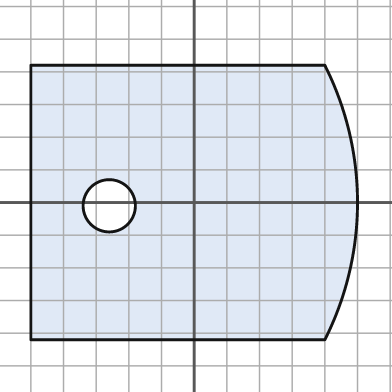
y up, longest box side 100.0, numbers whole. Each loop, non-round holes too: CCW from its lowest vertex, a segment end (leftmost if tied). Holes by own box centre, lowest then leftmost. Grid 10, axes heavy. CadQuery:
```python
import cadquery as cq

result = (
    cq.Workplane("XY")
    .moveTo(-50.0, -42.0)
    .lineTo(40.0, -42.0)
    .threePointArc((50.0, 0.0), (40.0, 42.0))
    .lineTo(-50.0, 42.0)
    .close()
    .moveTo(-26.0, -1.0)
    .circle(8.0)
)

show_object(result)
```